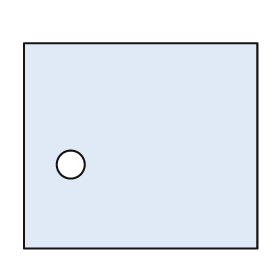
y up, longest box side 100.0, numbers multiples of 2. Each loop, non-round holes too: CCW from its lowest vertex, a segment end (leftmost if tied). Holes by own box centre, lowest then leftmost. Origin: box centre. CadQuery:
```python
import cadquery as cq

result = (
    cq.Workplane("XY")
    .moveTo(-50.0, -44.0)
    .lineTo(50.0, -44.0)
    .lineTo(50.0, 44.0)
    .lineTo(-50.0, 44.0)
    .close()
    .moveTo(-30.0, -8.0)
    .circle(6.0)
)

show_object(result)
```